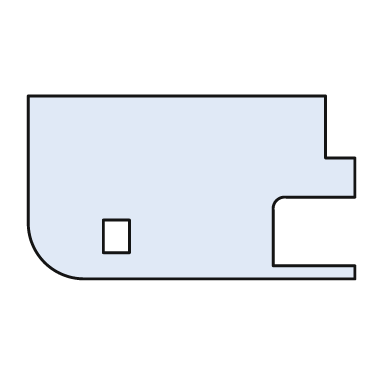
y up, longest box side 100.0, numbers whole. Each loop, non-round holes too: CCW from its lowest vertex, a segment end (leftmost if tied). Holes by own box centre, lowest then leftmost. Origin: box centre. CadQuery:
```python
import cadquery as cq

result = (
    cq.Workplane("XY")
    .moveTo(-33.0, -28.0)
    .lineTo(50.0, -28.0)
    .lineTo(50.0, -24.0)
    .lineTo(25.0, -24.0)
    .lineTo(25.0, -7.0)
    .threePointArc((26.0, -4.0), (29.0, -3.0))
    .lineTo(50.0, -3.0)
    .lineTo(50.0, 9.0)
    .lineTo(41.0, 9.0)
    .lineTo(41.0, 28.0)
    .lineTo(-50.0, 28.0)
    .lineTo(-50.0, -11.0)
    .threePointArc((-45.0, -23.0), (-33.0, -28.0))
    .close()
    .moveTo(-27.0, -20.0)
    .lineTo(-19.0, -20.0)
    .lineTo(-19.0, -10.0)
    .lineTo(-27.0, -10.0)
    .close()
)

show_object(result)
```